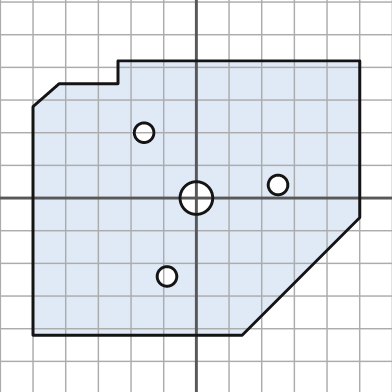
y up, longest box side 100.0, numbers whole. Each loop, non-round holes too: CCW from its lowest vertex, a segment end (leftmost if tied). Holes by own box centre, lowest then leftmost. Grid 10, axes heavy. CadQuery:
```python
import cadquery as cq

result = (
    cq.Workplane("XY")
    .moveTo(-50.0, -42.0)
    .lineTo(14.0, -42.0)
    .lineTo(50.0, -6.0)
    .lineTo(50.0, 42.0)
    .lineTo(-24.0, 42.0)
    .lineTo(-24.0, 35.0)
    .lineTo(-42.0, 35.0)
    .lineTo(-50.0, 28.0)
    .close()
    .moveTo(-9.0, -24.0)
    .circle(3.0)
    .moveTo(0.0, 0.0)
    .circle(5.0)
    .moveTo(25.0, 4.0)
    .circle(3.0)
    .moveTo(-16.0, 20.0)
    .circle(3.0)
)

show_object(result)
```